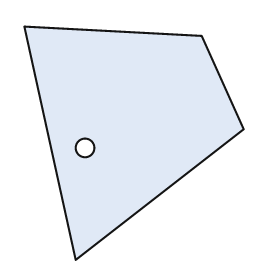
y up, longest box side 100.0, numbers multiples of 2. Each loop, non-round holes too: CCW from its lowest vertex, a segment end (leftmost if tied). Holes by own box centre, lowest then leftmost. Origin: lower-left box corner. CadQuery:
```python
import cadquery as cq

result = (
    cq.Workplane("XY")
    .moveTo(22.0, 0.0)
    .lineTo(94.0, 56.0)
    .lineTo(76.0, 96.0)
    .lineTo(0.0, 100.0)
    .close()
    .moveTo(26.0, 48.0)
    .circle(4.0)
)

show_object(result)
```